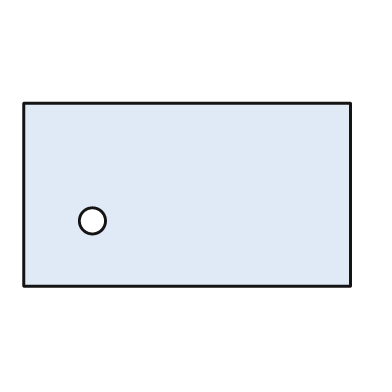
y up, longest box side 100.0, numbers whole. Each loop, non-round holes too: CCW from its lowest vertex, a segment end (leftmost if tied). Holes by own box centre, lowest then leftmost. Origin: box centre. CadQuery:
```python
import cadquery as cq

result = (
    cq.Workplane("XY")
    .moveTo(-50.0, -28.0)
    .lineTo(50.0, -28.0)
    .lineTo(50.0, 28.0)
    .lineTo(-50.0, 28.0)
    .close()
    .moveTo(-29.0, -8.0)
    .circle(4.0)
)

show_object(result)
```